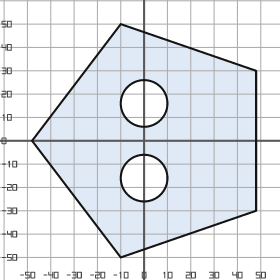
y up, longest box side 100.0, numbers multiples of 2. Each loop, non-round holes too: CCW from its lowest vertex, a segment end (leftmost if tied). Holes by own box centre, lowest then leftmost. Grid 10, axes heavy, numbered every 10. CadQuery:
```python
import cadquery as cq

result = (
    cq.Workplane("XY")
    .moveTo(-10.0, -50.0)
    .lineTo(48.0, -30.0)
    .lineTo(48.0, 30.0)
    .lineTo(-10.0, 50.0)
    .lineTo(-48.0, 0.0)
    .close()
    .moveTo(0.0, -16.0)
    .circle(10.0)
    .moveTo(0.0, 16.0)
    .circle(10.0)
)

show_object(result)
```